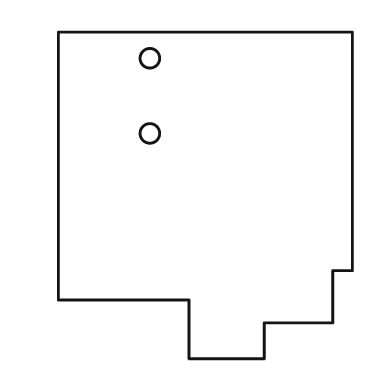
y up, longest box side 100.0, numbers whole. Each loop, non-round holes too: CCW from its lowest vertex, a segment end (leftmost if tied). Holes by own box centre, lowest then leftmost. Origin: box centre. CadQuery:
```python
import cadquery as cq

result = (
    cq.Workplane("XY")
    .moveTo(-5.0, -50.0)
    .lineTo(18.0, -50.0)
    .lineTo(18.0, -39.0)
    .lineTo(39.0, -39.0)
    .lineTo(39.0, -23.0)
    .lineTo(45.0, -23.0)
    .lineTo(45.0, 50.0)
    .lineTo(-45.0, 50.0)
    .lineTo(-45.0, -32.0)
    .lineTo(-5.0, -32.0)
    .close()
    .moveTo(-17.0, 19.0)
    .circle(3.0)
    .moveTo(-17.0, 42.0)
    .circle(3.0)
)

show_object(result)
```